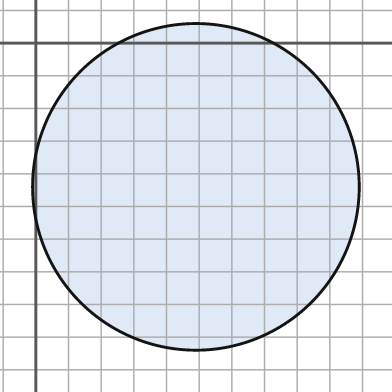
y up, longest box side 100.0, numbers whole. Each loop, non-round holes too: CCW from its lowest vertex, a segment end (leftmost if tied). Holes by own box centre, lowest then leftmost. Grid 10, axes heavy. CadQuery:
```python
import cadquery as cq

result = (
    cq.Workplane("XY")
    .moveTo(49.0, -44.0)
    .circle(50.0)
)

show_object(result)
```